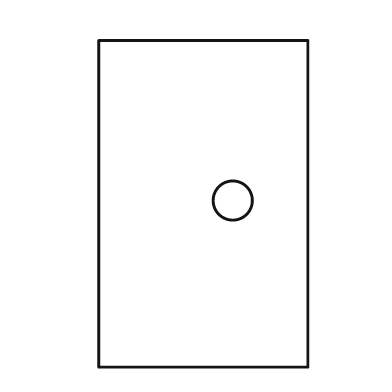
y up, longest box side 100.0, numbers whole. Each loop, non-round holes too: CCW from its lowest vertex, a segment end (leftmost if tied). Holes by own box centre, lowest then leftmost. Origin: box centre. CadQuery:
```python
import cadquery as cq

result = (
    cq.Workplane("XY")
    .moveTo(-32.0, -50.0)
    .lineTo(32.0, -50.0)
    .lineTo(32.0, 50.0)
    .lineTo(-32.0, 50.0)
    .close()
    .moveTo(9.0, 1.0)
    .circle(6.0)
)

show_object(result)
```